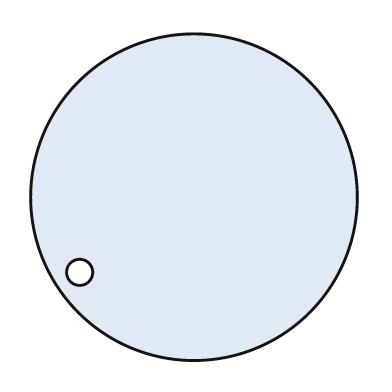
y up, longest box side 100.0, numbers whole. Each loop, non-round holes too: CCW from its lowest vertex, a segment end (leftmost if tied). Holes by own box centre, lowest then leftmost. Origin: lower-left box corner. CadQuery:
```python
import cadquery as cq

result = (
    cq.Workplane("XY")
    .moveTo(50.0, 50.0)
    .circle(50.0)
    .moveTo(15.0, 27.0)
    .circle(4.0)
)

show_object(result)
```